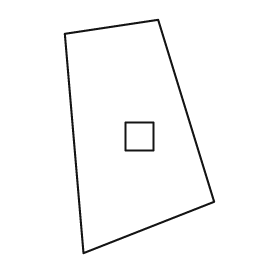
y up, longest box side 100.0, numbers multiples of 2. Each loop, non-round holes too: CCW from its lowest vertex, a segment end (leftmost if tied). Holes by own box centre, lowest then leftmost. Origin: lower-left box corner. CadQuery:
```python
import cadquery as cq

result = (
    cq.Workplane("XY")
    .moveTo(8.0, 0.0)
    .lineTo(64.0, 22.0)
    .lineTo(40.0, 100.0)
    .lineTo(0.0, 94.0)
    .close()
    .moveTo(26.0, 44.0)
    .lineTo(38.0, 44.0)
    .lineTo(38.0, 56.0)
    .lineTo(26.0, 56.0)
    .close()
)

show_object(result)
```